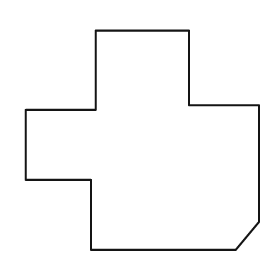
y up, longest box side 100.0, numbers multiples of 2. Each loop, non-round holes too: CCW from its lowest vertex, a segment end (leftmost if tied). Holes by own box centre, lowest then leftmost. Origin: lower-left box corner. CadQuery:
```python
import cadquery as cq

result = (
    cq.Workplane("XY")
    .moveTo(28.0, 0.0)
    .lineTo(90.0, 0.0)
    .lineTo(100.0, 12.0)
    .lineTo(100.0, 62.0)
    .lineTo(70.0, 62.0)
    .lineTo(70.0, 94.0)
    .lineTo(30.0, 94.0)
    .lineTo(30.0, 60.0)
    .lineTo(0.0, 60.0)
    .lineTo(0.0, 30.0)
    .lineTo(28.0, 30.0)
    .close()
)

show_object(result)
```